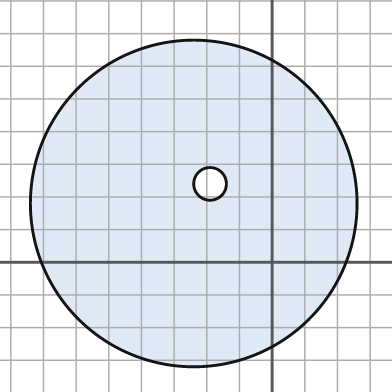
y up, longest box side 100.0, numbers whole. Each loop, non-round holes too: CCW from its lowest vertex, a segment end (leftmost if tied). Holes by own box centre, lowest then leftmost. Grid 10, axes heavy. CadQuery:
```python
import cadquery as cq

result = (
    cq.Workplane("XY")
    .moveTo(-24.0, 18.0)
    .circle(50.0)
    .moveTo(-19.0, 24.0)
    .circle(5.0)
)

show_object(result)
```